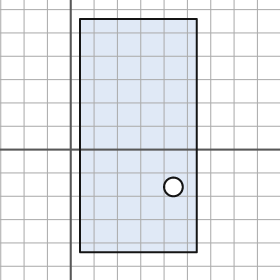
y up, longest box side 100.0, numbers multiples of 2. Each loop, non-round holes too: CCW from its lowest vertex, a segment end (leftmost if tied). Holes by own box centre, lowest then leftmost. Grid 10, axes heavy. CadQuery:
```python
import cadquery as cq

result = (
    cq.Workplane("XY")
    .moveTo(4.0, -44.0)
    .lineTo(54.0, -44.0)
    .lineTo(54.0, 56.0)
    .lineTo(4.0, 56.0)
    .close()
    .moveTo(44.0, -16.0)
    .circle(4.0)
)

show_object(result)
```